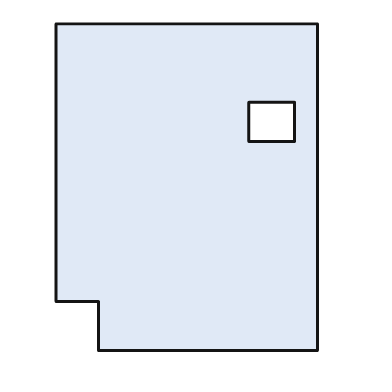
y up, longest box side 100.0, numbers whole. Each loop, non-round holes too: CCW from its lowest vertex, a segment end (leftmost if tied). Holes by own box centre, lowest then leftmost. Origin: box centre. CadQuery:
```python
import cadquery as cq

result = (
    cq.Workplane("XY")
    .moveTo(-27.0, -50.0)
    .lineTo(40.0, -50.0)
    .lineTo(40.0, 50.0)
    .lineTo(-40.0, 50.0)
    .lineTo(-40.0, -35.0)
    .lineTo(-27.0, -35.0)
    .close()
    .moveTo(19.0, 14.0)
    .lineTo(33.0, 14.0)
    .lineTo(33.0, 26.0)
    .lineTo(19.0, 26.0)
    .close()
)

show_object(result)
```